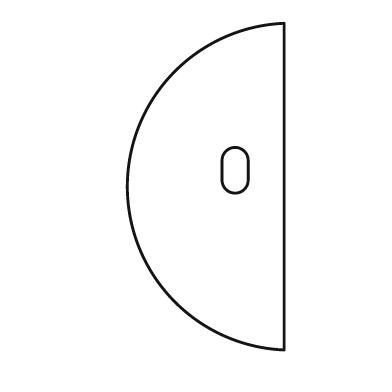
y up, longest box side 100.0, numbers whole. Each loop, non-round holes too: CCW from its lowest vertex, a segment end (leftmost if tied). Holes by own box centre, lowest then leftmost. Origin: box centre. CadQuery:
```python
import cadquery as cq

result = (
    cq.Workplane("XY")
    .moveTo(24.0, -50.0)
    .lineTo(24.0, 50.0)
    .threePointArc((-24.0, 0.0), (24.0, -50.0))
    .close()
    .moveTo(5.0, 2.0)
    .threePointArc((9.0, -2.0), (13.0, 2.0))
    .lineTo(13.0, 8.0)
    .threePointArc((9.0, 12.0), (5.0, 8.0))
    .close()
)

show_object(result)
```